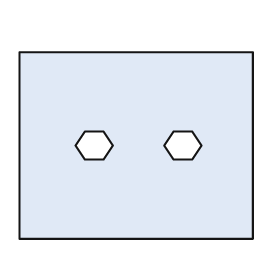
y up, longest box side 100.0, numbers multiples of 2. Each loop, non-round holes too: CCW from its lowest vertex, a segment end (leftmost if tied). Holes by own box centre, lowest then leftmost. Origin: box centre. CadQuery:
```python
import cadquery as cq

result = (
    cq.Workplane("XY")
    .moveTo(-50.0, -40.0)
    .lineTo(50.0, -40.0)
    .lineTo(50.0, 40.0)
    .lineTo(-50.0, 40.0)
    .close()
    .moveTo(-22.0, -6.0)
    .lineTo(-14.0, -6.0)
    .lineTo(-10.0, 0.0)
    .lineTo(-14.0, 6.0)
    .lineTo(-22.0, 6.0)
    .lineTo(-26.0, 0.0)
    .close()
    .moveTo(16.0, -6.0)
    .lineTo(24.0, -6.0)
    .lineTo(28.0, 0.0)
    .lineTo(24.0, 6.0)
    .lineTo(16.0, 6.0)
    .lineTo(12.0, 0.0)
    .close()
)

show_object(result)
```